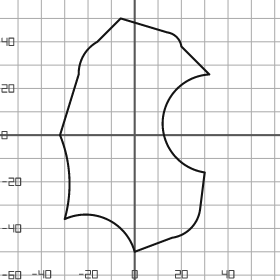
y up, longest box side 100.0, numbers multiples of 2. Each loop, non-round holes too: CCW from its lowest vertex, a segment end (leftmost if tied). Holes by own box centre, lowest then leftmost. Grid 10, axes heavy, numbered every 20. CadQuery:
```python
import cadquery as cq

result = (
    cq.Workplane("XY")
    .moveTo(0.0, -50.0)
    .lineTo(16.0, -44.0)
    .threePointArc((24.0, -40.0), (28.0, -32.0))
    .lineTo(30.0, -16.0)
    .threePointArc((12.0, 6.0), (32.0, 26.0))
    .lineTo(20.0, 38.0)
    .threePointArc((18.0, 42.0), (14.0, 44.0))
    .lineTo(-6.0, 50.0)
    .lineTo(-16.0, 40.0)
    .threePointArc((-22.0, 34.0), (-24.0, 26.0))
    .lineTo(-32.0, 0.0)
    .threePointArc((-28.0, -18.0), (-30.0, -36.0))
    .threePointArc((-12.0, -36.0), (0.0, -50.0))
    .close()
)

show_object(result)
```